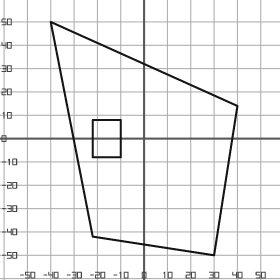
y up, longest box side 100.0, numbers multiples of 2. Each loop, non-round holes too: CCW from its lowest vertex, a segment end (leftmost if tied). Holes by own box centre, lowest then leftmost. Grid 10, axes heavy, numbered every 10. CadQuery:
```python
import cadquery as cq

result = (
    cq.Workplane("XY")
    .moveTo(30.0, -50.0)
    .lineTo(40.0, 14.0)
    .lineTo(-40.0, 50.0)
    .lineTo(-22.0, -42.0)
    .close()
    .moveTo(-22.0, -8.0)
    .lineTo(-10.0, -8.0)
    .lineTo(-10.0, 8.0)
    .lineTo(-22.0, 8.0)
    .close()
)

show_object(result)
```